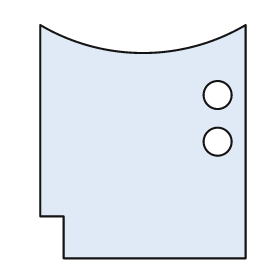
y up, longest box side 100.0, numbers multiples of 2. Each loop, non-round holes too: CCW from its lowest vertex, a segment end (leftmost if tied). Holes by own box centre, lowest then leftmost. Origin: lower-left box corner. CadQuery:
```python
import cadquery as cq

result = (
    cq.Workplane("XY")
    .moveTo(10.0, 0.0)
    .lineTo(88.0, 0.0)
    .lineTo(88.0, 100.0)
    .threePointArc((44.0, 88.0), (0.0, 100.0))
    .lineTo(0.0, 18.0)
    .lineTo(10.0, 18.0)
    .close()
    .moveTo(76.0, 50.0)
    .circle(6.0)
    .moveTo(76.0, 70.0)
    .circle(6.0)
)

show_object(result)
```